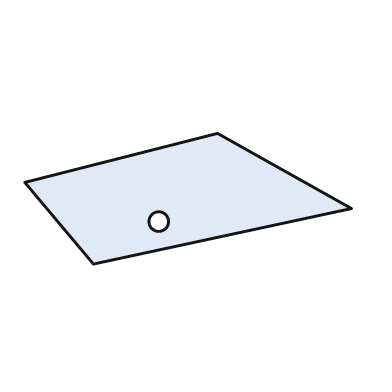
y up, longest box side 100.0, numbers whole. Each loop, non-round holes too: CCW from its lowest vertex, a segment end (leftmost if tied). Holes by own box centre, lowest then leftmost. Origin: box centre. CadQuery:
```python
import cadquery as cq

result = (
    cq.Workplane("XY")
    .moveTo(-29.0, -20.0)
    .lineTo(50.0, -3.0)
    .lineTo(9.0, 20.0)
    .lineTo(-50.0, 5.0)
    .close()
    .moveTo(-9.0, -7.0)
    .circle(3.0)
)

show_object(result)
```